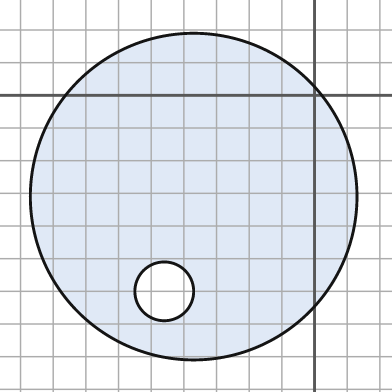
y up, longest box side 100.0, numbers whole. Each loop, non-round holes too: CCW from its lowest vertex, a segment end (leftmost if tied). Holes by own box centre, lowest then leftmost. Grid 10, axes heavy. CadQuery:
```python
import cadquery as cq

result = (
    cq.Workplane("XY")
    .moveTo(-37.0, -31.0)
    .circle(50.0)
    .moveTo(-46.0, -60.0)
    .circle(9.0)
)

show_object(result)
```